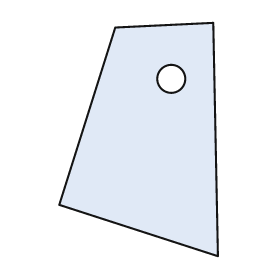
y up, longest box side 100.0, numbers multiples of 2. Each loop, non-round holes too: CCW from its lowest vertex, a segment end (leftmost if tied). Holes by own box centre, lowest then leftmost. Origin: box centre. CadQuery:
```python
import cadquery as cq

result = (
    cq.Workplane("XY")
    .moveTo(34.0, -50.0)
    .lineTo(32.0, 50.0)
    .lineTo(-10.0, 48.0)
    .lineTo(-34.0, -28.0)
    .close()
    .moveTo(14.0, 26.0)
    .circle(6.0)
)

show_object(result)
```